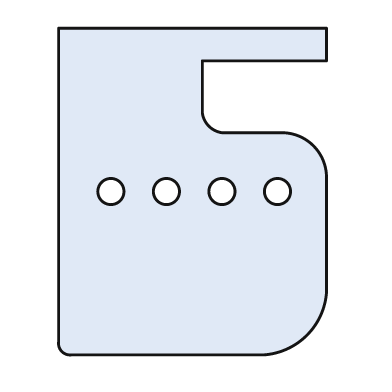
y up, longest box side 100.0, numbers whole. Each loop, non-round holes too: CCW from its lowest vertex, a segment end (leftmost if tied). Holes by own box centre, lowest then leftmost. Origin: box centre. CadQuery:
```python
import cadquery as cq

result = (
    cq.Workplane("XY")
    .moveTo(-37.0, -50.0)
    .lineTo(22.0, -50.0)
    .threePointArc((35.0, -44.0), (41.0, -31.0))
    .lineTo(41.0, 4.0)
    .threePointArc((37.0, 14.0), (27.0, 18.0))
    .lineTo(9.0, 18.0)
    .threePointArc((5.0, 20.0), (3.0, 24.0))
    .lineTo(3.0, 40.0)
    .lineTo(41.0, 40.0)
    .lineTo(41.0, 50.0)
    .lineTo(-41.0, 50.0)
    .lineTo(-41.0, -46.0)
    .threePointArc((-40.0, -49.0), (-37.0, -50.0))
    .close()
    .moveTo(-25.0, 0.0)
    .circle(4.0)
    .moveTo(-8.0, 0.0)
    .circle(4.0)
    .moveTo(9.0, 0.0)
    .circle(4.0)
    .moveTo(26.0, 0.0)
    .circle(4.0)
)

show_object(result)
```